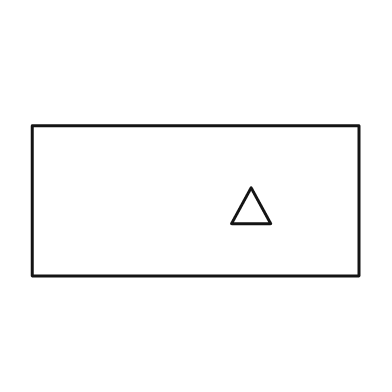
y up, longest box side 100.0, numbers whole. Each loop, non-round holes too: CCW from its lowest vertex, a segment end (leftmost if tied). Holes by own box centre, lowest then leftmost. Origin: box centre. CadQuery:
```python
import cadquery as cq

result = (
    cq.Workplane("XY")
    .moveTo(-50.0, -23.0)
    .lineTo(50.0, -23.0)
    .lineTo(50.0, 23.0)
    .lineTo(-50.0, 23.0)
    .close()
    .moveTo(11.0, -7.0)
    .lineTo(23.0, -7.0)
    .lineTo(17.0, 4.0)
    .close()
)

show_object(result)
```